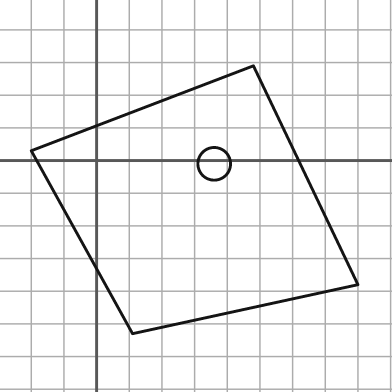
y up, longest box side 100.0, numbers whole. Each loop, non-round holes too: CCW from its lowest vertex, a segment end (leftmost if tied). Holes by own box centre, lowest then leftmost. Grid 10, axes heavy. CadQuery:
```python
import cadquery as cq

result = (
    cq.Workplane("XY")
    .moveTo(11.0, -53.0)
    .lineTo(80.0, -38.0)
    .lineTo(48.0, 29.0)
    .lineTo(-20.0, 3.0)
    .close()
    .moveTo(36.0, -1.0)
    .circle(5.0)
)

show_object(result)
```